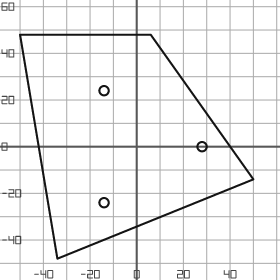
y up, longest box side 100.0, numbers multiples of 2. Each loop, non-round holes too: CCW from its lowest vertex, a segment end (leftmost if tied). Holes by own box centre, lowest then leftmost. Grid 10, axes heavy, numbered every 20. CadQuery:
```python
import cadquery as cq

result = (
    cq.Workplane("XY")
    .moveTo(-34.0, -48.0)
    .lineTo(50.0, -14.0)
    .lineTo(6.0, 48.0)
    .lineTo(-50.0, 48.0)
    .close()
    .moveTo(-14.0, -24.0)
    .circle(2.0)
    .moveTo(28.0, 0.0)
    .circle(2.0)
    .moveTo(-14.0, 24.0)
    .circle(2.0)
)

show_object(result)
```